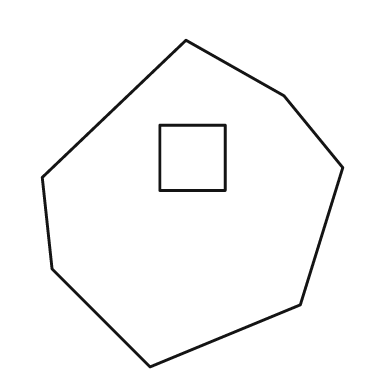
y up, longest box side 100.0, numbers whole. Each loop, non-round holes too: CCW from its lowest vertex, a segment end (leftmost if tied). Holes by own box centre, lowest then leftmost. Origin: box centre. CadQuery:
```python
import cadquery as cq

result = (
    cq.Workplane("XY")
    .moveTo(-13.0, -50.0)
    .lineTo(33.0, -31.0)
    .lineTo(46.0, 11.0)
    .lineTo(28.0, 33.0)
    .lineTo(-2.0, 50.0)
    .lineTo(-46.0, 8.0)
    .lineTo(-43.0, -20.0)
    .close()
    .moveTo(-10.0, 4.0)
    .lineTo(10.0, 4.0)
    .lineTo(10.0, 24.0)
    .lineTo(-10.0, 24.0)
    .close()
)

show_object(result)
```